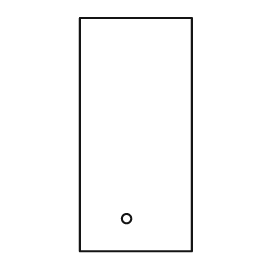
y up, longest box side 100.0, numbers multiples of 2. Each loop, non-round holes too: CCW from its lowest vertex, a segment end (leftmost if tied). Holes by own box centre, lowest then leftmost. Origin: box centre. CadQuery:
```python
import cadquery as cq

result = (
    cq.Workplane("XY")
    .moveTo(-24.0, -50.0)
    .lineTo(24.0, -50.0)
    .lineTo(24.0, 50.0)
    .lineTo(-24.0, 50.0)
    .close()
    .moveTo(-4.0, -36.0)
    .circle(2.0)
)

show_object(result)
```